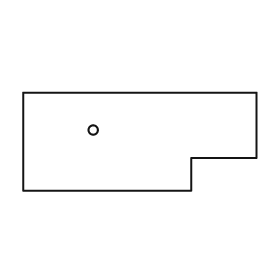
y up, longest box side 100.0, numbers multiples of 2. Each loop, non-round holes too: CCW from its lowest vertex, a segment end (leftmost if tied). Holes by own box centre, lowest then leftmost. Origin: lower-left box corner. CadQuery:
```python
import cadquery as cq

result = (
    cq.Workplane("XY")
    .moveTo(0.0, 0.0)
    .lineTo(72.0, 0.0)
    .lineTo(72.0, 14.0)
    .lineTo(100.0, 14.0)
    .lineTo(100.0, 42.0)
    .lineTo(0.0, 42.0)
    .close()
    .moveTo(30.0, 26.0)
    .circle(2.0)
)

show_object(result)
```